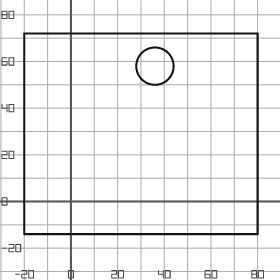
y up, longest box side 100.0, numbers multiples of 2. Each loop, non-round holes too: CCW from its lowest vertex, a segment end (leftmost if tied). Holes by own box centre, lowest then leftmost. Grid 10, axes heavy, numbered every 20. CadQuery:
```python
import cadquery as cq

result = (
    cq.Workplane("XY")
    .moveTo(-20.0, -14.0)
    .lineTo(80.0, -14.0)
    .lineTo(80.0, 72.0)
    .lineTo(-20.0, 72.0)
    .close()
    .moveTo(36.0, 58.0)
    .circle(8.0)
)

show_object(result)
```